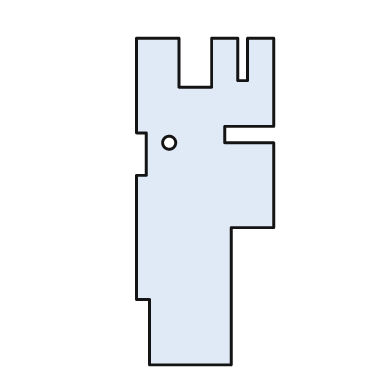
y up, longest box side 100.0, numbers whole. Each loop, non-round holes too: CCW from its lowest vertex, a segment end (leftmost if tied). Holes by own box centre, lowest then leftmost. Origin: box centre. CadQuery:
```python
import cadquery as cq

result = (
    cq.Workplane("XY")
    .moveTo(-17.0, -50.0)
    .lineTo(8.0, -50.0)
    .lineTo(8.0, -8.0)
    .lineTo(21.0, -8.0)
    .lineTo(21.0, 18.0)
    .lineTo(6.0, 18.0)
    .lineTo(6.0, 23.0)
    .lineTo(21.0, 23.0)
    .lineTo(21.0, 50.0)
    .lineTo(13.0, 50.0)
    .lineTo(13.0, 37.0)
    .lineTo(10.0, 37.0)
    .lineTo(10.0, 50.0)
    .lineTo(2.0, 50.0)
    .lineTo(2.0, 35.0)
    .lineTo(-8.0, 35.0)
    .lineTo(-8.0, 50.0)
    .lineTo(-21.0, 50.0)
    .lineTo(-21.0, 21.0)
    .lineTo(-18.0, 21.0)
    .lineTo(-18.0, 8.0)
    .lineTo(-21.0, 8.0)
    .lineTo(-21.0, -30.0)
    .lineTo(-17.0, -30.0)
    .close()
    .moveTo(-11.0, 18.0)
    .circle(2.0)
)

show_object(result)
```